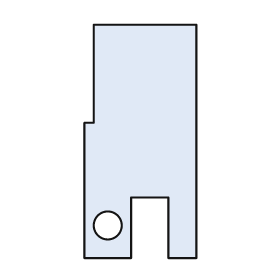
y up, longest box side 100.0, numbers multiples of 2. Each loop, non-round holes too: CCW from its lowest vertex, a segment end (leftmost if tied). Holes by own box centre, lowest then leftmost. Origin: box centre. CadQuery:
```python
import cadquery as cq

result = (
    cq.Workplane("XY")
    .moveTo(-24.0, -50.0)
    .lineTo(-4.0, -50.0)
    .lineTo(-4.0, -24.0)
    .lineTo(12.0, -24.0)
    .lineTo(12.0, -50.0)
    .lineTo(24.0, -50.0)
    .lineTo(24.0, 50.0)
    .lineTo(-20.0, 50.0)
    .lineTo(-20.0, 8.0)
    .lineTo(-24.0, 8.0)
    .close()
    .moveTo(-14.0, -36.0)
    .circle(6.0)
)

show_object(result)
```